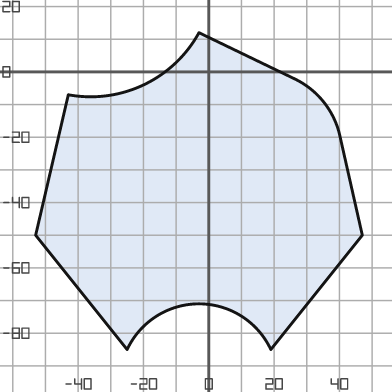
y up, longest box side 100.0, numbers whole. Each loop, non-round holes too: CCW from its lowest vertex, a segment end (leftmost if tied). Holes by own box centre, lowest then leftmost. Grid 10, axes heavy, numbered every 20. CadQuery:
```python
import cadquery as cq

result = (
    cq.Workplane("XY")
    .moveTo(-25.0, -85.0)
    .threePointArc((-3.0, -71.0), (19.0, -85.0))
    .lineTo(47.0, -50.0)
    .lineTo(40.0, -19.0)
    .threePointArc((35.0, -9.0), (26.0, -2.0))
    .lineTo(-3.0, 12.0)
    .threePointArc((-20.0, -4.0), (-43.0, -7.0))
    .lineTo(-53.0, -50.0)
    .close()
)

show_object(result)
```